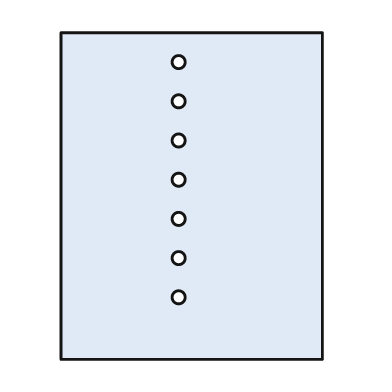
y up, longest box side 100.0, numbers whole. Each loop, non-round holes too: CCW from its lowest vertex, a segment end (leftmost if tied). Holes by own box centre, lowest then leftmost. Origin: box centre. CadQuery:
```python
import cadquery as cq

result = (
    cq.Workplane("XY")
    .moveTo(-40.0, -50.0)
    .lineTo(40.0, -50.0)
    .lineTo(40.0, 50.0)
    .lineTo(-40.0, 50.0)
    .close()
    .moveTo(-4.0, -31.0)
    .circle(2.0)
    .moveTo(-4.0, -19.0)
    .circle(2.0)
    .moveTo(-4.0, -7.0)
    .circle(2.0)
    .moveTo(-4.0, 5.0)
    .circle(2.0)
    .moveTo(-4.0, 17.0)
    .circle(2.0)
    .moveTo(-4.0, 29.0)
    .circle(2.0)
    .moveTo(-4.0, 41.0)
    .circle(2.0)
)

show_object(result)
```